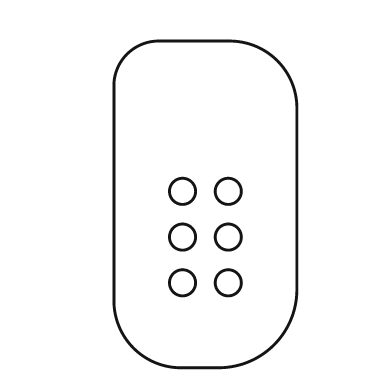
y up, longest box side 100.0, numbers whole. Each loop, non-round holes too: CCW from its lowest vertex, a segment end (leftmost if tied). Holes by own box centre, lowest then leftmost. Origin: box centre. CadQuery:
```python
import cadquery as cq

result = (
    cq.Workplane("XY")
    .moveTo(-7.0, -50.0)
    .lineTo(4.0, -50.0)
    .threePointArc((21.0, -43.0), (28.0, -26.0))
    .lineTo(28.0, 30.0)
    .threePointArc((22.0, 44.0), (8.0, 50.0))
    .lineTo(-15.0, 50.0)
    .threePointArc((-24.0, 46.0), (-28.0, 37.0))
    .lineTo(-28.0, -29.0)
    .threePointArc((-22.0, -44.0), (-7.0, -50.0))
    .close()
    .moveTo(-7.0, -24.0)
    .circle(4.0)
    .moveTo(7.0, -24.0)
    .circle(4.0)
    .moveTo(-7.0, -10.0)
    .circle(4.0)
    .moveTo(7.0, -10.0)
    .circle(4.0)
    .moveTo(-7.0, 4.0)
    .circle(4.0)
    .moveTo(7.0, 4.0)
    .circle(4.0)
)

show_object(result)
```